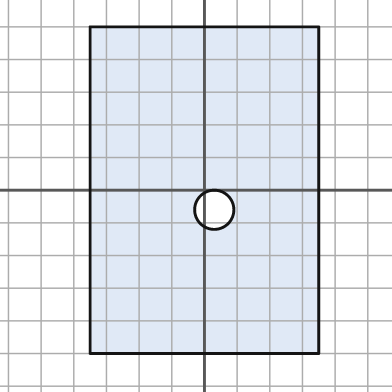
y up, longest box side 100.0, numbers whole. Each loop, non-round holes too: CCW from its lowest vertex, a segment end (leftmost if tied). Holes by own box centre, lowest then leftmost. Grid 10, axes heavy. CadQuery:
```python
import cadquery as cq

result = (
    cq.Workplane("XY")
    .moveTo(-35.0, -50.0)
    .lineTo(35.0, -50.0)
    .lineTo(35.0, 50.0)
    .lineTo(-35.0, 50.0)
    .close()
    .moveTo(3.0, -6.0)
    .circle(6.0)
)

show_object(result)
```